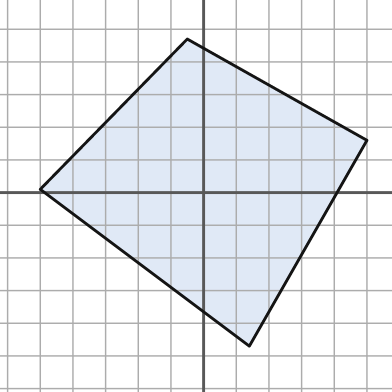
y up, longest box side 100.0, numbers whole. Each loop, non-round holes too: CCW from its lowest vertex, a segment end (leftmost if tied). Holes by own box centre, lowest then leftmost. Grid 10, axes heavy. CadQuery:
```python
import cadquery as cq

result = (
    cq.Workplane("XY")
    .moveTo(14.0, -47.0)
    .lineTo(50.0, 16.0)
    .lineTo(-5.0, 47.0)
    .lineTo(-50.0, 1.0)
    .close()
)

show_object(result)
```